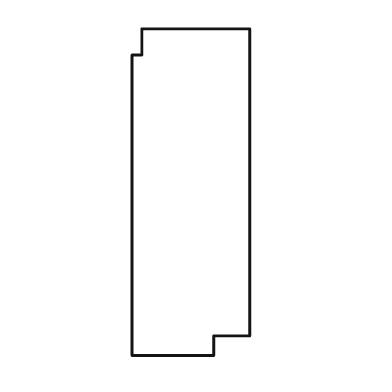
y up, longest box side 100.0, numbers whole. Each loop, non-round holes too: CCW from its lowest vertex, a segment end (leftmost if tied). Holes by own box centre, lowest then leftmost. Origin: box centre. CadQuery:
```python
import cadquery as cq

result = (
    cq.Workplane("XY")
    .moveTo(-18.0, -50.0)
    .lineTo(7.0, -50.0)
    .lineTo(7.0, -44.0)
    .lineTo(18.0, -44.0)
    .lineTo(18.0, 50.0)
    .lineTo(-15.0, 50.0)
    .lineTo(-15.0, 42.0)
    .lineTo(-18.0, 42.0)
    .close()
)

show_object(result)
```